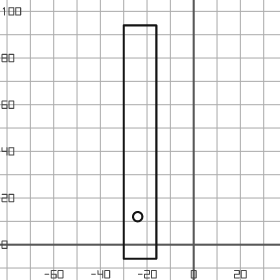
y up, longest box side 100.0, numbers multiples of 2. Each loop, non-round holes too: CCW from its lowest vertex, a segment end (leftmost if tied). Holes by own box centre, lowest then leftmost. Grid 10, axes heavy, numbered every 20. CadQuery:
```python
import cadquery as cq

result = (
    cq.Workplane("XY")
    .moveTo(-30.0, -6.0)
    .lineTo(-16.0, -6.0)
    .lineTo(-16.0, 94.0)
    .lineTo(-30.0, 94.0)
    .close()
    .moveTo(-24.0, 12.0)
    .circle(2.0)
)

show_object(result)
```